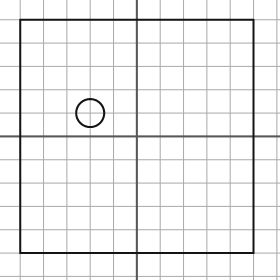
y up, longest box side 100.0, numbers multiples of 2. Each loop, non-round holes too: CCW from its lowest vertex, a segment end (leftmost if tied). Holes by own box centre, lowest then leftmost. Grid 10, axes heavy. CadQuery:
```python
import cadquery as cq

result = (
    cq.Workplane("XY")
    .moveTo(-50.0, -50.0)
    .lineTo(50.0, -50.0)
    .lineTo(50.0, 50.0)
    .lineTo(-50.0, 50.0)
    .close()
    .moveTo(-20.0, 10.0)
    .circle(6.0)
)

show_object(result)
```